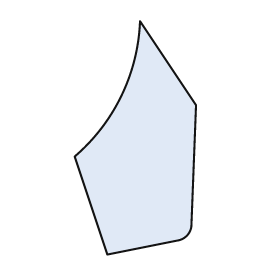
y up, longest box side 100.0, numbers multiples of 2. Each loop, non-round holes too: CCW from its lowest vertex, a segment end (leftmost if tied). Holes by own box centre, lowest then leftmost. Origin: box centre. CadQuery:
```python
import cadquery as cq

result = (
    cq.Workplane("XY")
    .moveTo(-12.0, -50.0)
    .lineTo(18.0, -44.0)
    .threePointArc((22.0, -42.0), (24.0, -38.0))
    .lineTo(26.0, 14.0)
    .lineTo(2.0, 50.0)
    .threePointArc((-6.0, 18.0), (-26.0, -8.0))
    .close()
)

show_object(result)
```